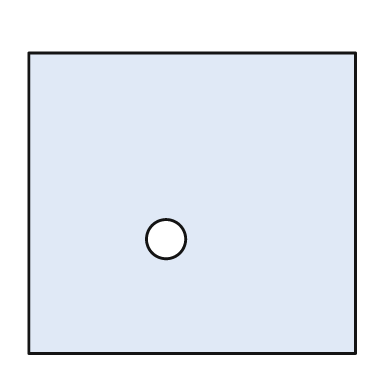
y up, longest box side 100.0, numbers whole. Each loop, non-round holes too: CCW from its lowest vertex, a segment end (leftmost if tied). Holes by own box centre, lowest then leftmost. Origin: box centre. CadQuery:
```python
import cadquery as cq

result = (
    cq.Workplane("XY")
    .moveTo(-50.0, -46.0)
    .lineTo(50.0, -46.0)
    .lineTo(50.0, 46.0)
    .lineTo(-50.0, 46.0)
    .close()
    .moveTo(-8.0, -11.0)
    .circle(6.0)
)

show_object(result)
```